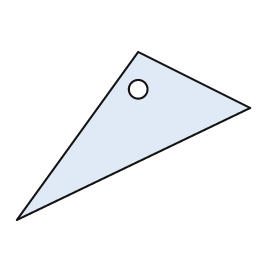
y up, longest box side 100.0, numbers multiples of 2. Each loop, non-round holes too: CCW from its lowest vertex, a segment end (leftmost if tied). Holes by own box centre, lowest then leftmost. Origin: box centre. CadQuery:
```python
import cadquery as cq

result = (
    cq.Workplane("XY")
    .moveTo(-50.0, -36.0)
    .lineTo(50.0, 12.0)
    .lineTo(2.0, 36.0)
    .close()
    .moveTo(2.0, 20.0)
    .circle(4.0)
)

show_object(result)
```